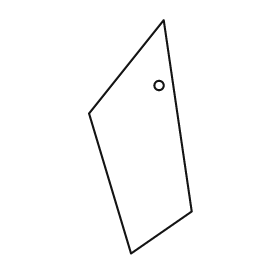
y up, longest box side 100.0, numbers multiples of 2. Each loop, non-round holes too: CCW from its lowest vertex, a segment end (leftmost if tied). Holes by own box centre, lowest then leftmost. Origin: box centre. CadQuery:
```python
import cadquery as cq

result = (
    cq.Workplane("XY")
    .moveTo(-4.0, -50.0)
    .lineTo(22.0, -32.0)
    .lineTo(10.0, 50.0)
    .lineTo(-22.0, 10.0)
    .close()
    .moveTo(8.0, 22.0)
    .circle(2.0)
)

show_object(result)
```